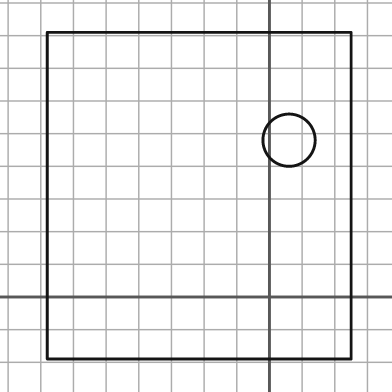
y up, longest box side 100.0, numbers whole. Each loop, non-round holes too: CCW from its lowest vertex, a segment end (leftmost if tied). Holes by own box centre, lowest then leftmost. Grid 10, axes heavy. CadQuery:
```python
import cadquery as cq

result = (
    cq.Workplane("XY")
    .moveTo(-68.0, -19.0)
    .lineTo(25.0, -19.0)
    .lineTo(25.0, 81.0)
    .lineTo(-68.0, 81.0)
    .close()
    .moveTo(6.0, 48.0)
    .circle(8.0)
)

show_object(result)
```